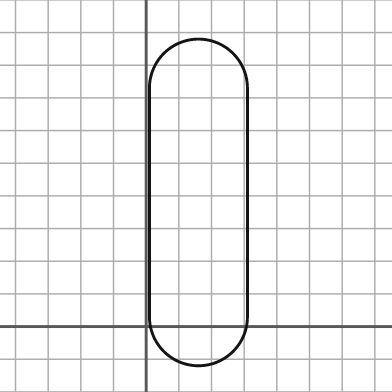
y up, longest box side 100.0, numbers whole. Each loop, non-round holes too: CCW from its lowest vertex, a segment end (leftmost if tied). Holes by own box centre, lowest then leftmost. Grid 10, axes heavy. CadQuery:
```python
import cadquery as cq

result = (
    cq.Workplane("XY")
    .moveTo(1.0, 3.0)
    .threePointArc((16.0, -12.0), (31.0, 3.0))
    .lineTo(31.0, 73.0)
    .threePointArc((16.0, 88.0), (1.0, 73.0))
    .close()
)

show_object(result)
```